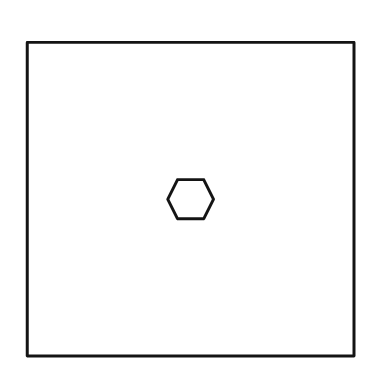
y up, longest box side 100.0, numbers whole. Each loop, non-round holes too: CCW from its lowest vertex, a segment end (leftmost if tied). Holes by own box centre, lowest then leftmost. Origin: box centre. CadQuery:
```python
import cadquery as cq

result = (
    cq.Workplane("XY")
    .moveTo(-50.0, -48.0)
    .lineTo(50.0, -48.0)
    .lineTo(50.0, 48.0)
    .lineTo(-50.0, 48.0)
    .close()
    .moveTo(-4.0, -6.0)
    .lineTo(4.0, -6.0)
    .lineTo(7.0, 0.0)
    .lineTo(4.0, 6.0)
    .lineTo(-4.0, 6.0)
    .lineTo(-7.0, 0.0)
    .close()
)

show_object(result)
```